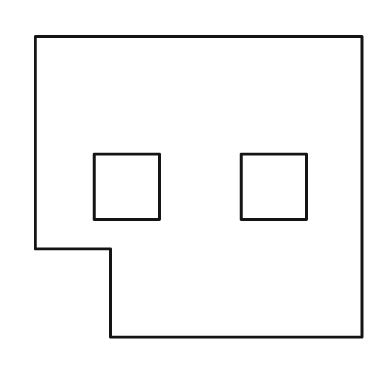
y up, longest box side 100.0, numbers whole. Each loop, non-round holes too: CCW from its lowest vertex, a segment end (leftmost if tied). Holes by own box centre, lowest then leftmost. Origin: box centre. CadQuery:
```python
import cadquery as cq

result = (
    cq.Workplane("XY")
    .moveTo(-27.0, -46.0)
    .lineTo(50.0, -46.0)
    .lineTo(50.0, 46.0)
    .lineTo(-50.0, 46.0)
    .lineTo(-50.0, -19.0)
    .lineTo(-27.0, -19.0)
    .close()
    .moveTo(-32.0, -10.0)
    .lineTo(-12.0, -10.0)
    .lineTo(-12.0, 10.0)
    .lineTo(-32.0, 10.0)
    .close()
    .moveTo(13.0, -10.0)
    .lineTo(33.0, -10.0)
    .lineTo(33.0, 10.0)
    .lineTo(13.0, 10.0)
    .close()
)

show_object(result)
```